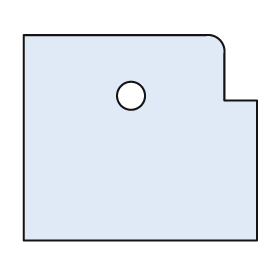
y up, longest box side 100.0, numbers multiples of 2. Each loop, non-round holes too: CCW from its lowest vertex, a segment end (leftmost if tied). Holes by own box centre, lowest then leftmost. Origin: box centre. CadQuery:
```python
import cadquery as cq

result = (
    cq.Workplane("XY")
    .moveTo(-50.0, -44.0)
    .lineTo(50.0, -44.0)
    .lineTo(50.0, 16.0)
    .lineTo(36.0, 16.0)
    .lineTo(36.0, 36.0)
    .threePointArc((34.0, 42.0), (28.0, 44.0))
    .lineTo(-50.0, 44.0)
    .close()
    .moveTo(-4.0, 18.0)
    .circle(6.0)
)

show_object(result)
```